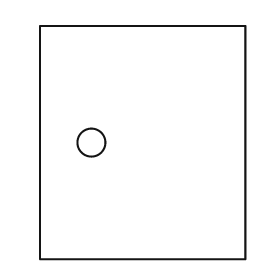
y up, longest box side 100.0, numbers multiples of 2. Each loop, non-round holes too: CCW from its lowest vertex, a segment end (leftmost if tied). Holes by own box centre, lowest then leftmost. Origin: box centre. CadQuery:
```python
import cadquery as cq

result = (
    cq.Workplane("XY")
    .moveTo(-44.0, -50.0)
    .lineTo(44.0, -50.0)
    .lineTo(44.0, 50.0)
    .lineTo(-44.0, 50.0)
    .close()
    .moveTo(-22.0, 0.0)
    .circle(6.0)
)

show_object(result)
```